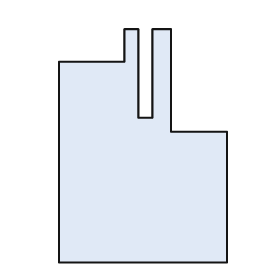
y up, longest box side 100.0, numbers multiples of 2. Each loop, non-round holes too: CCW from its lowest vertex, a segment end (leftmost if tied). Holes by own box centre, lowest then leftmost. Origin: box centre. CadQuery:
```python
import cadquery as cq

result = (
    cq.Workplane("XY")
    .moveTo(-36.0, -50.0)
    .lineTo(36.0, -50.0)
    .lineTo(36.0, 6.0)
    .lineTo(12.0, 6.0)
    .lineTo(12.0, 50.0)
    .lineTo(4.0, 50.0)
    .lineTo(4.0, 12.0)
    .lineTo(-2.0, 12.0)
    .lineTo(-2.0, 50.0)
    .lineTo(-8.0, 50.0)
    .lineTo(-8.0, 36.0)
    .lineTo(-36.0, 36.0)
    .close()
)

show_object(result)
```